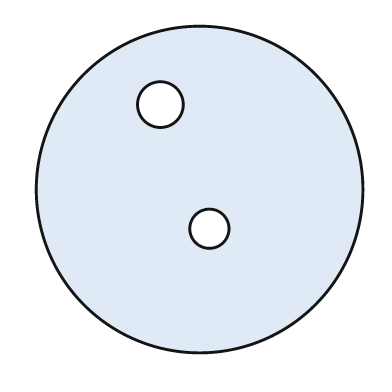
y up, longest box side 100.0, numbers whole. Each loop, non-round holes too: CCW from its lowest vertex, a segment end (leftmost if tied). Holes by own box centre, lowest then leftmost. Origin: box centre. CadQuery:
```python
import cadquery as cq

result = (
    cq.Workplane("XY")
    .moveTo(0.0, 0.0)
    .circle(50.0)
    .moveTo(3.0, -12.0)
    .circle(6.0)
    .moveTo(-12.0, 26.0)
    .circle(7.0)
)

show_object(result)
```